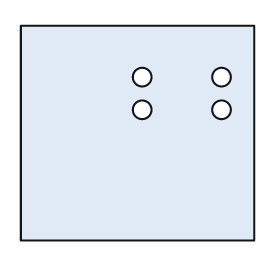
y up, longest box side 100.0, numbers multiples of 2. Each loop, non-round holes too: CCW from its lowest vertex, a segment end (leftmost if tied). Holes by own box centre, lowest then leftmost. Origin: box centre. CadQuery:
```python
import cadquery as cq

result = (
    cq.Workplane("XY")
    .moveTo(-50.0, -46.0)
    .lineTo(50.0, -46.0)
    .lineTo(50.0, 46.0)
    .lineTo(-50.0, 46.0)
    .close()
    .moveTo(2.0, 10.0)
    .circle(4.0)
    .moveTo(36.0, 10.0)
    .circle(4.0)
    .moveTo(2.0, 24.0)
    .circle(4.0)
    .moveTo(36.0, 24.0)
    .circle(4.0)
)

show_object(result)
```